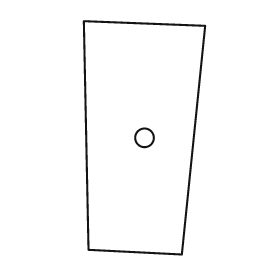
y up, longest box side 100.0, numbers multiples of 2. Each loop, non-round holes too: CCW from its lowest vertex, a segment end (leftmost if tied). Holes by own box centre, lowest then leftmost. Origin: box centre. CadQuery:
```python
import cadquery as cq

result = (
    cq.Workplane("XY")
    .moveTo(16.0, -50.0)
    .lineTo(26.0, 48.0)
    .lineTo(-26.0, 50.0)
    .lineTo(-24.0, -48.0)
    .close()
    .moveTo(0.0, 0.0)
    .circle(4.0)
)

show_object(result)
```